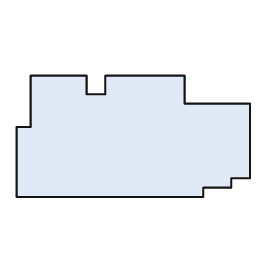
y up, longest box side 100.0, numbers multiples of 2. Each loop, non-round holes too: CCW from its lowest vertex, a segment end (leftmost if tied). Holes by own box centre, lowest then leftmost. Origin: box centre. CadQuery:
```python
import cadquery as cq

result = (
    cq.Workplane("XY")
    .moveTo(-50.0, -26.0)
    .lineTo(30.0, -26.0)
    .lineTo(30.0, -22.0)
    .lineTo(42.0, -22.0)
    .lineTo(42.0, -18.0)
    .lineTo(50.0, -18.0)
    .lineTo(50.0, 14.0)
    .lineTo(22.0, 14.0)
    .lineTo(22.0, 26.0)
    .lineTo(-12.0, 26.0)
    .lineTo(-12.0, 18.0)
    .lineTo(-20.0, 18.0)
    .lineTo(-20.0, 26.0)
    .lineTo(-44.0, 26.0)
    .lineTo(-44.0, 4.0)
    .lineTo(-50.0, 4.0)
    .close()
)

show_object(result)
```